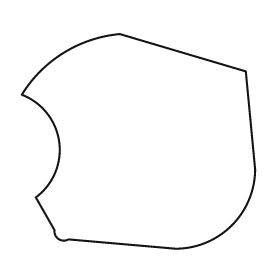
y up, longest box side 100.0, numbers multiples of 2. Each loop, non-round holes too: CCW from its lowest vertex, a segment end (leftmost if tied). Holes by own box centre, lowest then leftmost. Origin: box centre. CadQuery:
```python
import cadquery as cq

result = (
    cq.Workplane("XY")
    .moveTo(16.0, -46.0)
    .threePointArc((40.0, -36.0), (50.0, -12.0))
    .lineTo(46.0, 30.0)
    .lineTo(-8.0, 46.0)
    .threePointArc((-32.0, 38.0), (-50.0, 20.0))
    .threePointArc((-34.0, 0.0), (-44.0, -24.0))
    .lineTo(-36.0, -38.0)
    .threePointArc((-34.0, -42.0), (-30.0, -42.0))
    .close()
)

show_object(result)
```